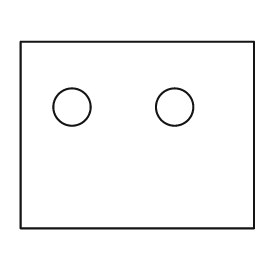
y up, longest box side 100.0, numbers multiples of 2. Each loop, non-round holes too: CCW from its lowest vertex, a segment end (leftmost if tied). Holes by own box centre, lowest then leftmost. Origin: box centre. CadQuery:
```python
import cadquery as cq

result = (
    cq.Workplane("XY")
    .moveTo(-50.0, -40.0)
    .lineTo(50.0, -40.0)
    .lineTo(50.0, 40.0)
    .lineTo(-50.0, 40.0)
    .close()
    .moveTo(-28.0, 12.0)
    .circle(8.0)
    .moveTo(16.0, 12.0)
    .circle(8.0)
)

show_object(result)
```